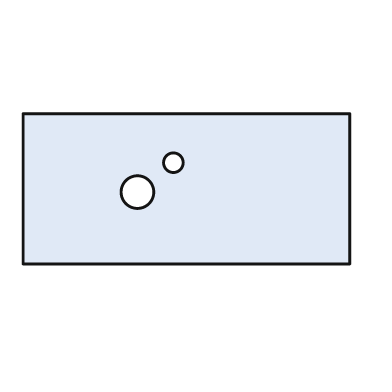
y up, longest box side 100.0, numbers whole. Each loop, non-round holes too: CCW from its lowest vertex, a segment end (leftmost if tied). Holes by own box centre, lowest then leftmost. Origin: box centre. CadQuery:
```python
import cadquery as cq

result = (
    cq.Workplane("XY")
    .moveTo(-50.0, -23.0)
    .lineTo(50.0, -23.0)
    .lineTo(50.0, 23.0)
    .lineTo(-50.0, 23.0)
    .close()
    .moveTo(-15.0, -1.0)
    .circle(5.0)
    .moveTo(-4.0, 8.0)
    .circle(3.0)
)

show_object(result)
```